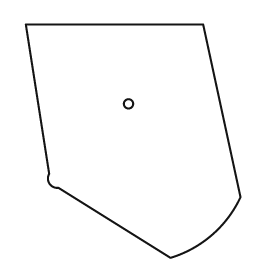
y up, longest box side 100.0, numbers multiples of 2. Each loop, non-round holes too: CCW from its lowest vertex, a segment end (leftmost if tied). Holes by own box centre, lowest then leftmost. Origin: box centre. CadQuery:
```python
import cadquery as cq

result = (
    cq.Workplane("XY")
    .moveTo(16.0, -50.0)
    .threePointArc((34.0, -40.0), (46.0, -24.0))
    .lineTo(30.0, 50.0)
    .lineTo(-46.0, 50.0)
    .lineTo(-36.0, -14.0)
    .threePointArc((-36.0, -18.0), (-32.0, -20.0))
    .close()
    .moveTo(-2.0, 16.0)
    .circle(2.0)
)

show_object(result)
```